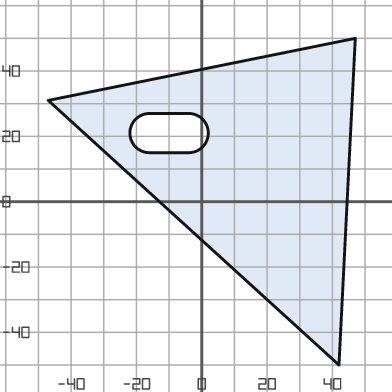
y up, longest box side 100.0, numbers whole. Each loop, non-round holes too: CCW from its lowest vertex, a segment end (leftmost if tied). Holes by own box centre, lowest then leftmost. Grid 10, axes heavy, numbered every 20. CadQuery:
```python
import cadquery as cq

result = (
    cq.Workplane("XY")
    .moveTo(42.0, -50.0)
    .lineTo(47.0, 50.0)
    .lineTo(-47.0, 31.0)
    .close()
    .moveTo(-16.0, 15.0)
    .lineTo(-4.0, 15.0)
    .threePointArc((2.0, 21.0), (-4.0, 27.0))
    .lineTo(-16.0, 27.0)
    .threePointArc((-22.0, 21.0), (-16.0, 15.0))
    .close()
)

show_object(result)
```